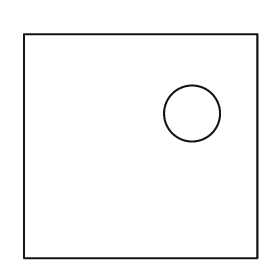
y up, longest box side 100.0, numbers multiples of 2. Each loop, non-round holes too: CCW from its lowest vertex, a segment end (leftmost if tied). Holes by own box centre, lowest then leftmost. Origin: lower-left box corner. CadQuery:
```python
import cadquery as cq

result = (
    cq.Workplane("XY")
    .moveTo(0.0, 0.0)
    .lineTo(100.0, 0.0)
    .lineTo(100.0, 96.0)
    .lineTo(0.0, 96.0)
    .close()
    .moveTo(72.0, 62.0)
    .circle(12.0)
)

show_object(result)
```